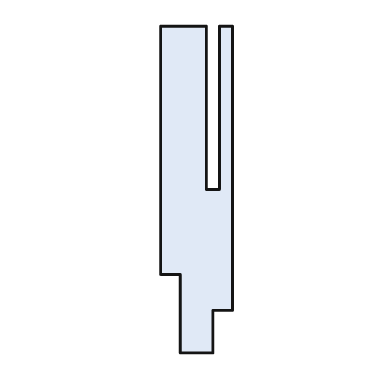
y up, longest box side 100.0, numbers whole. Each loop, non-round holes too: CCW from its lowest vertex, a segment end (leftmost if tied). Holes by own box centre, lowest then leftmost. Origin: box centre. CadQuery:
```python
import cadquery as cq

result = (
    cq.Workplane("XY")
    .moveTo(-5.0, -50.0)
    .lineTo(5.0, -50.0)
    .lineTo(5.0, -37.0)
    .lineTo(11.0, -37.0)
    .lineTo(11.0, 50.0)
    .lineTo(7.0, 50.0)
    .lineTo(7.0, 0.0)
    .lineTo(3.0, 0.0)
    .lineTo(3.0, 50.0)
    .lineTo(-11.0, 50.0)
    .lineTo(-11.0, -26.0)
    .lineTo(-5.0, -26.0)
    .close()
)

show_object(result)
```